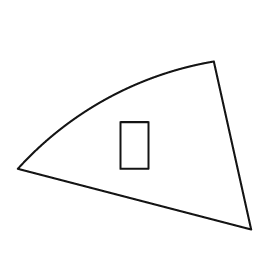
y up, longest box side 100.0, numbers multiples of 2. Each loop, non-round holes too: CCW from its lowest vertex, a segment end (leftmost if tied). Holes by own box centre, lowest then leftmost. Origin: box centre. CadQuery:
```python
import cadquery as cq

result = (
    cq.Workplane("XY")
    .moveTo(50.0, -36.0)
    .lineTo(34.0, 36.0)
    .threePointArc((-12.0, 20.0), (-50.0, -10.0))
    .close()
    .moveTo(-6.0, -10.0)
    .lineTo(6.0, -10.0)
    .lineTo(6.0, 10.0)
    .lineTo(-6.0, 10.0)
    .close()
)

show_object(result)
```